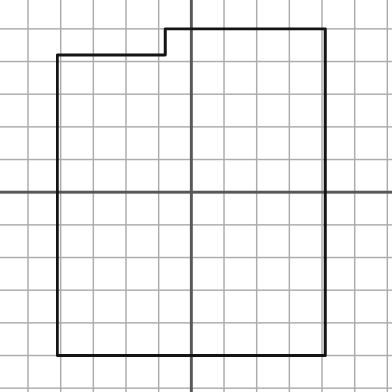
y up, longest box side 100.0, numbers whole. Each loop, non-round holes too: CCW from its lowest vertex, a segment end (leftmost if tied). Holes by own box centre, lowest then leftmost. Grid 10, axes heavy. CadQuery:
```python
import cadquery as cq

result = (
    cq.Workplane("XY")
    .moveTo(-41.0, -50.0)
    .lineTo(41.0, -50.0)
    .lineTo(41.0, 50.0)
    .lineTo(-8.0, 50.0)
    .lineTo(-8.0, 42.0)
    .lineTo(-41.0, 42.0)
    .close()
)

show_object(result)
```